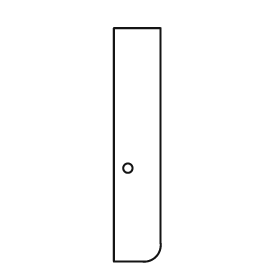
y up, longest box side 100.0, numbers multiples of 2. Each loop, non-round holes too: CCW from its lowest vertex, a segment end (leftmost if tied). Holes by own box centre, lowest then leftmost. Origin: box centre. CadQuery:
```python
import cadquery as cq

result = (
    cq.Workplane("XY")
    .moveTo(-10.0, -50.0)
    .lineTo(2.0, -50.0)
    .threePointArc((8.0, -48.0), (10.0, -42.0))
    .lineTo(10.0, 50.0)
    .lineTo(-10.0, 50.0)
    .close()
    .moveTo(-4.0, -10.0)
    .circle(2.0)
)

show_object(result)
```